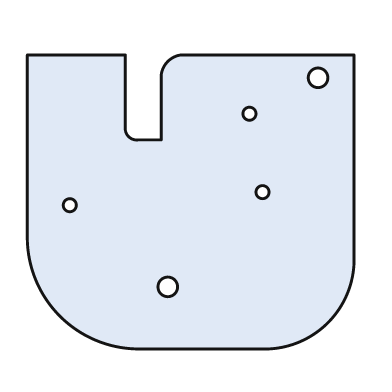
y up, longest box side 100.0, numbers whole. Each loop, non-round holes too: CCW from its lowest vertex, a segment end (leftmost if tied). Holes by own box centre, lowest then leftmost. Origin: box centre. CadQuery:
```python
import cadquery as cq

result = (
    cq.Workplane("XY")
    .moveTo(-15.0, -45.0)
    .lineTo(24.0, -45.0)
    .threePointArc((42.0, -37.0), (50.0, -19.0))
    .lineTo(50.0, 45.0)
    .lineTo(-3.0, 45.0)
    .threePointArc((-7.0, 43.0), (-9.0, 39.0))
    .lineTo(-9.0, 19.0)
    .lineTo(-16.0, 19.0)
    .threePointArc((-19.0, 20.0), (-20.0, 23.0))
    .lineTo(-20.0, 45.0)
    .lineTo(-50.0, 45.0)
    .lineTo(-50.0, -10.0)
    .threePointArc((-40.0, -35.0), (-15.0, -45.0))
    .close()
    .moveTo(-7.0, -26.0)
    .circle(3.0)
    .moveTo(-37.0, -1.0)
    .circle(2.0)
    .moveTo(22.0, 3.0)
    .circle(2.0)
    .moveTo(18.0, 27.0)
    .circle(2.0)
    .moveTo(39.0, 38.0)
    .circle(3.0)
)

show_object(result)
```